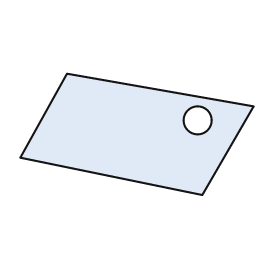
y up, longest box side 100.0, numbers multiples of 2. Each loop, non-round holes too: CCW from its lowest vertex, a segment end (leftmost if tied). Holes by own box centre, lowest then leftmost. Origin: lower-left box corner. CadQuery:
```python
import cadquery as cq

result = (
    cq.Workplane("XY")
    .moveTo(78.0, 0.0)
    .lineTo(100.0, 38.0)
    .lineTo(20.0, 52.0)
    .lineTo(0.0, 16.0)
    .close()
    .moveTo(76.0, 32.0)
    .circle(6.0)
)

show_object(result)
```